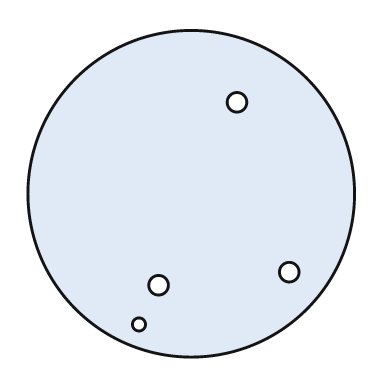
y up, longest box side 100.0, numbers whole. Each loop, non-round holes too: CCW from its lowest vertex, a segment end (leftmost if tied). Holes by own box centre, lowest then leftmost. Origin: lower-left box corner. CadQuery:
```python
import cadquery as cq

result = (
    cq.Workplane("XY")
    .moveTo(50.0, 50.0)
    .circle(50.0)
    .moveTo(34.0, 10.0)
    .circle(2.0)
    .moveTo(40.0, 22.0)
    .circle(3.0)
    .moveTo(80.0, 26.0)
    .circle(3.0)
    .moveTo(64.0, 78.0)
    .circle(3.0)
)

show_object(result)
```